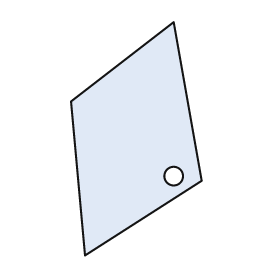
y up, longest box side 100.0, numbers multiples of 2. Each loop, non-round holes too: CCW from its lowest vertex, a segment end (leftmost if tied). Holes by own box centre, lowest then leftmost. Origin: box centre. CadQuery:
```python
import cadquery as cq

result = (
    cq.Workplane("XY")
    .moveTo(-22.0, -50.0)
    .lineTo(28.0, -18.0)
    .lineTo(16.0, 50.0)
    .lineTo(-28.0, 16.0)
    .close()
    .moveTo(16.0, -16.0)
    .circle(4.0)
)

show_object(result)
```